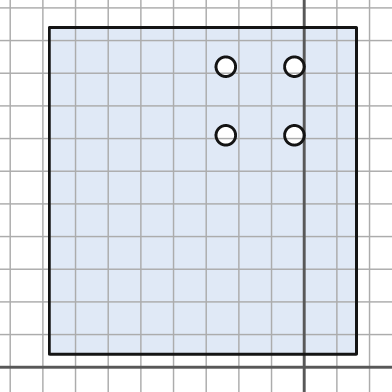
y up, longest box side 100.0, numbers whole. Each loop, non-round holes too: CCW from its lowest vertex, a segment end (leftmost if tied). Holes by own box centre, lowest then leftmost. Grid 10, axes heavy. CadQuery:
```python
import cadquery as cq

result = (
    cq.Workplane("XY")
    .moveTo(-78.0, 4.0)
    .lineTo(16.0, 4.0)
    .lineTo(16.0, 104.0)
    .lineTo(-78.0, 104.0)
    .close()
    .moveTo(-24.0, 71.0)
    .circle(3.0)
    .moveTo(-3.0, 71.0)
    .circle(3.0)
    .moveTo(-24.0, 92.0)
    .circle(3.0)
    .moveTo(-3.0, 92.0)
    .circle(3.0)
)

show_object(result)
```